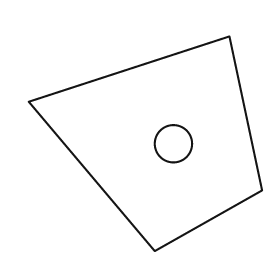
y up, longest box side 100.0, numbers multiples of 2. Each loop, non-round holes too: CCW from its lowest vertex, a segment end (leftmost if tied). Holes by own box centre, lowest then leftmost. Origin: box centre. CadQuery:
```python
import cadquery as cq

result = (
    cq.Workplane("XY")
    .moveTo(4.0, -46.0)
    .lineTo(50.0, -20.0)
    .lineTo(36.0, 46.0)
    .lineTo(-50.0, 18.0)
    .close()
    .moveTo(12.0, 0.0)
    .circle(8.0)
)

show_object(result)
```